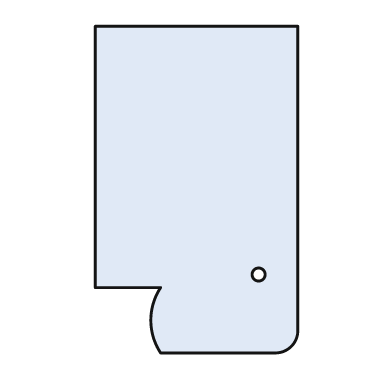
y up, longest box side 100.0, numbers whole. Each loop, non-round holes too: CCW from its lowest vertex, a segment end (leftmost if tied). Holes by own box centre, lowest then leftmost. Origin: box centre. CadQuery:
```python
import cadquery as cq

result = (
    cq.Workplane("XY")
    .moveTo(-11.0, -50.0)
    .lineTo(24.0, -50.0)
    .threePointArc((29.0, -48.0), (31.0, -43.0))
    .lineTo(31.0, 50.0)
    .lineTo(-31.0, 50.0)
    .lineTo(-31.0, -30.0)
    .lineTo(-11.0, -30.0)
    .threePointArc((-14.0, -40.0), (-11.0, -50.0))
    .close()
    .moveTo(19.0, -26.0)
    .circle(2.0)
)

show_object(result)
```